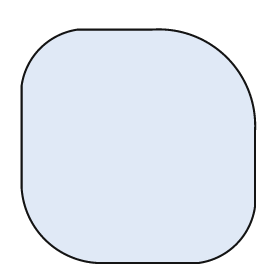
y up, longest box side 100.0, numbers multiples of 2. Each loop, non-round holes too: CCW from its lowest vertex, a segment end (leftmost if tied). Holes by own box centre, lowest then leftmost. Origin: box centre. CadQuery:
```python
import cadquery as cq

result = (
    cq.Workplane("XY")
    .moveTo(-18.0, -50.0)
    .lineTo(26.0, -50.0)
    .threePointArc((42.0, -42.0), (50.0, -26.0))
    .lineTo(50.0, 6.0)
    .threePointArc((38.0, 38.0), (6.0, 50.0))
    .lineTo(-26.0, 50.0)
    .threePointArc((-42.0, 42.0), (-50.0, 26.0))
    .lineTo(-50.0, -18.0)
    .threePointArc((-40.0, -40.0), (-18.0, -50.0))
    .close()
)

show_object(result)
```